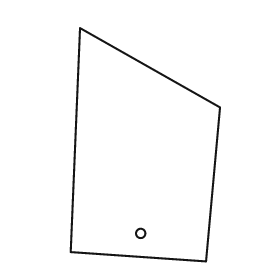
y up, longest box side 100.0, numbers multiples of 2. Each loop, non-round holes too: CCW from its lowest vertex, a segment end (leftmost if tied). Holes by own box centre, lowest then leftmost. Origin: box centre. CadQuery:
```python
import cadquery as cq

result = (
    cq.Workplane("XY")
    .moveTo(26.0, -50.0)
    .lineTo(32.0, 16.0)
    .lineTo(-28.0, 50.0)
    .lineTo(-32.0, -46.0)
    .close()
    .moveTo(-2.0, -38.0)
    .circle(2.0)
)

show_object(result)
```